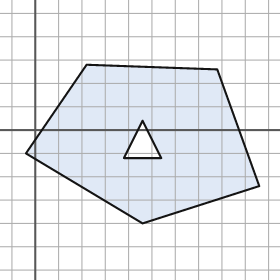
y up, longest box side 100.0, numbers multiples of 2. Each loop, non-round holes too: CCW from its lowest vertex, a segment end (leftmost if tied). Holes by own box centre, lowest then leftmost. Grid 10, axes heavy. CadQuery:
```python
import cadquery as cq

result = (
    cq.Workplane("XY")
    .moveTo(46.0, -40.0)
    .lineTo(96.0, -24.0)
    .lineTo(78.0, 26.0)
    .lineTo(22.0, 28.0)
    .lineTo(-4.0, -10.0)
    .close()
    .moveTo(38.0, -12.0)
    .lineTo(54.0, -12.0)
    .lineTo(46.0, 4.0)
    .close()
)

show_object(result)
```